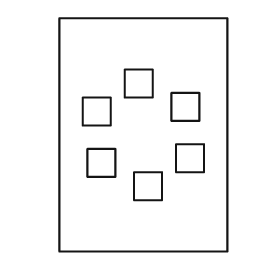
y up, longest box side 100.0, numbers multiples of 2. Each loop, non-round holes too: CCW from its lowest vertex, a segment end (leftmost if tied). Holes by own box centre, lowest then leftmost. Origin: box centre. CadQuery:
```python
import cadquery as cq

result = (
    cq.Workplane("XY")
    .moveTo(-36.0, -50.0)
    .lineTo(36.0, -50.0)
    .lineTo(36.0, 50.0)
    .lineTo(-36.0, 50.0)
    .close()
    .moveTo(-4.0, -28.0)
    .lineTo(8.0, -28.0)
    .lineTo(8.0, -16.0)
    .lineTo(-4.0, -16.0)
    .close()
    .moveTo(-24.0, -18.0)
    .lineTo(-12.0, -18.0)
    .lineTo(-12.0, -6.0)
    .lineTo(-24.0, -6.0)
    .close()
    .moveTo(14.0, -16.0)
    .lineTo(26.0, -16.0)
    .lineTo(26.0, -4.0)
    .lineTo(14.0, -4.0)
    .close()
    .moveTo(-26.0, 4.0)
    .lineTo(-14.0, 4.0)
    .lineTo(-14.0, 16.0)
    .lineTo(-26.0, 16.0)
    .close()
    .moveTo(12.0, 6.0)
    .lineTo(24.0, 6.0)
    .lineTo(24.0, 18.0)
    .lineTo(12.0, 18.0)
    .close()
    .moveTo(-8.0, 16.0)
    .lineTo(4.0, 16.0)
    .lineTo(4.0, 28.0)
    .lineTo(-8.0, 28.0)
    .close()
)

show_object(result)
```